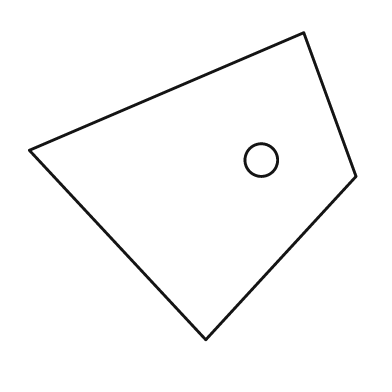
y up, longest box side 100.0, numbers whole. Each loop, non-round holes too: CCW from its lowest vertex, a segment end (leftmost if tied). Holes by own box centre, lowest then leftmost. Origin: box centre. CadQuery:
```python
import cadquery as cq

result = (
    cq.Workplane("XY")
    .moveTo(4.0, -47.0)
    .lineTo(50.0, 3.0)
    .lineTo(34.0, 47.0)
    .lineTo(-50.0, 11.0)
    .close()
    .moveTo(21.0, 8.0)
    .circle(5.0)
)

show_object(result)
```